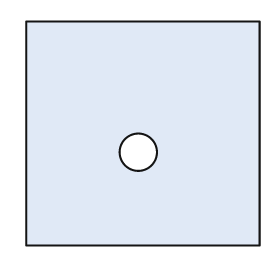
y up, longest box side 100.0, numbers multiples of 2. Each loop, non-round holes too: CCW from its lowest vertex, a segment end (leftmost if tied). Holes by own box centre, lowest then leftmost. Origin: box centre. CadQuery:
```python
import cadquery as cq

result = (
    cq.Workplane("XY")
    .moveTo(-50.0, -48.0)
    .lineTo(50.0, -48.0)
    .lineTo(50.0, 48.0)
    .lineTo(-50.0, 48.0)
    .close()
    .moveTo(-2.0, -8.0)
    .circle(8.0)
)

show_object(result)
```